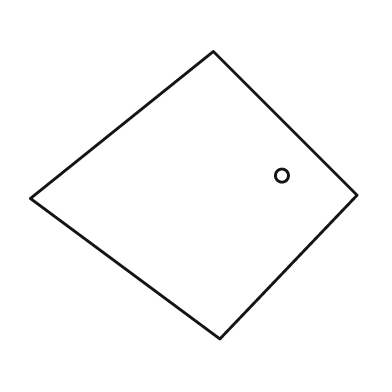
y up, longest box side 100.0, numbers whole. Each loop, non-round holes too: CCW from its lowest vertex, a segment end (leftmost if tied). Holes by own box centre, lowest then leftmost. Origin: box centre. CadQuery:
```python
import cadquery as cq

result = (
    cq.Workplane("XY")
    .moveTo(8.0, -44.0)
    .lineTo(50.0, 0.0)
    .lineTo(6.0, 44.0)
    .lineTo(-50.0, -1.0)
    .close()
    .moveTo(27.0, 6.0)
    .circle(2.0)
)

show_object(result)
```